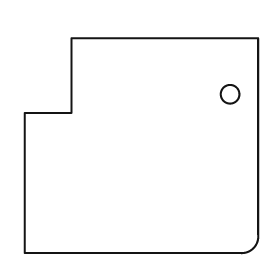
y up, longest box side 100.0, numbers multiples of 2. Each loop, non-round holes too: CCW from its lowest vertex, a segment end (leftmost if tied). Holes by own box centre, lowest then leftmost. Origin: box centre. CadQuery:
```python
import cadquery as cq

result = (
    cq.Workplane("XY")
    .moveTo(-50.0, -46.0)
    .lineTo(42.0, -46.0)
    .threePointArc((48.0, -44.0), (50.0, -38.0))
    .lineTo(50.0, 46.0)
    .lineTo(-30.0, 46.0)
    .lineTo(-30.0, 14.0)
    .lineTo(-50.0, 14.0)
    .close()
    .moveTo(38.0, 22.0)
    .circle(4.0)
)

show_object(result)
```